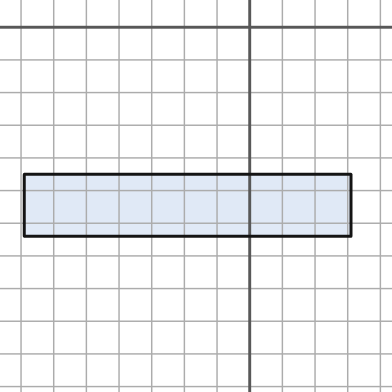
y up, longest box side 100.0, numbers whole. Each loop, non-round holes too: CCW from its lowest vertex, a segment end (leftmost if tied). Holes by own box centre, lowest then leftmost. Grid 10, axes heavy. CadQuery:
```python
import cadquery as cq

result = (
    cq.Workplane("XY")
    .moveTo(-69.0, -64.0)
    .lineTo(31.0, -64.0)
    .lineTo(31.0, -45.0)
    .lineTo(-69.0, -45.0)
    .close()
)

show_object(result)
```